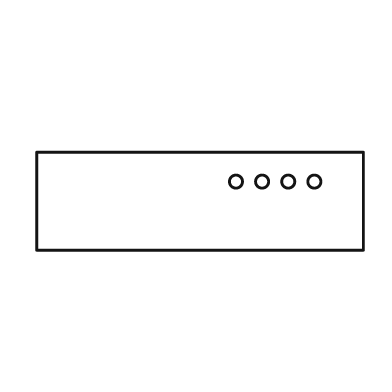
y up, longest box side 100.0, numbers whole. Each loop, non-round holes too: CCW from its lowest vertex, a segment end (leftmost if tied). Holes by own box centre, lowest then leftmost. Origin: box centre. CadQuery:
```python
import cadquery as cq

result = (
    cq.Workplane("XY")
    .moveTo(-50.0, -15.0)
    .lineTo(50.0, -15.0)
    .lineTo(50.0, 15.0)
    .lineTo(-50.0, 15.0)
    .close()
    .moveTo(11.0, 6.0)
    .circle(2.0)
    .moveTo(19.0, 6.0)
    .circle(2.0)
    .moveTo(27.0, 6.0)
    .circle(2.0)
    .moveTo(35.0, 6.0)
    .circle(2.0)
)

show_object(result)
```